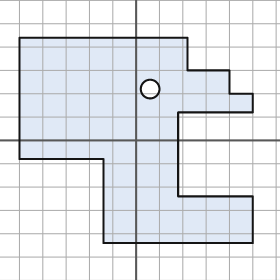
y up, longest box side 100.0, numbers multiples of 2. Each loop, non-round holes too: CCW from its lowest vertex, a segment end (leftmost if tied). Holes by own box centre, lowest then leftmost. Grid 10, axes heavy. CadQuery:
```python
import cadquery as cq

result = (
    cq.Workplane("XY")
    .moveTo(-14.0, -44.0)
    .lineTo(50.0, -44.0)
    .lineTo(50.0, -24.0)
    .lineTo(18.0, -24.0)
    .lineTo(18.0, 12.0)
    .lineTo(50.0, 12.0)
    .lineTo(50.0, 20.0)
    .lineTo(40.0, 20.0)
    .lineTo(40.0, 30.0)
    .lineTo(22.0, 30.0)
    .lineTo(22.0, 44.0)
    .lineTo(-50.0, 44.0)
    .lineTo(-50.0, -8.0)
    .lineTo(-14.0, -8.0)
    .close()
    .moveTo(6.0, 22.0)
    .circle(4.0)
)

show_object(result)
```